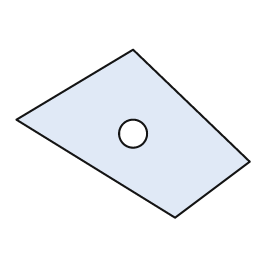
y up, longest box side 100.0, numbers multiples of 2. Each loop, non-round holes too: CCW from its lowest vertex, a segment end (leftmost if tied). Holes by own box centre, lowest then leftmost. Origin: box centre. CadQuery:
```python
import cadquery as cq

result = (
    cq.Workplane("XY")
    .moveTo(18.0, -36.0)
    .lineTo(50.0, -12.0)
    .lineTo(0.0, 36.0)
    .lineTo(-50.0, 6.0)
    .close()
    .moveTo(0.0, 0.0)
    .circle(6.0)
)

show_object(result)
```